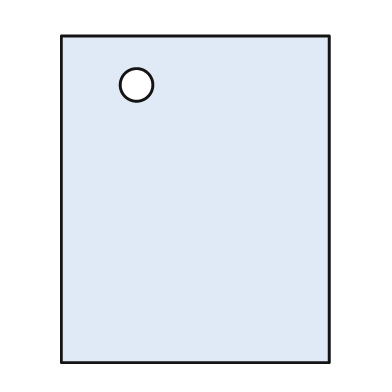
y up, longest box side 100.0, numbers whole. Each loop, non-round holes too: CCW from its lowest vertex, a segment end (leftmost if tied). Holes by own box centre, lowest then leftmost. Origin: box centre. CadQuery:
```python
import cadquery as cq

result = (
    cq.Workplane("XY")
    .moveTo(-41.0, -50.0)
    .lineTo(41.0, -50.0)
    .lineTo(41.0, 50.0)
    .lineTo(-41.0, 50.0)
    .close()
    .moveTo(-18.0, 35.0)
    .circle(5.0)
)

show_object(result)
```